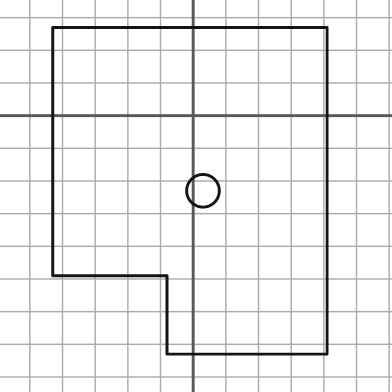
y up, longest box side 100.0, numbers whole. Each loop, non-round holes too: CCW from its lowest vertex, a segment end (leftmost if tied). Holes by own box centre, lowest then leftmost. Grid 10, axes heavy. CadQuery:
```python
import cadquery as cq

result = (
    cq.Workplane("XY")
    .moveTo(-8.0, -73.0)
    .lineTo(41.0, -73.0)
    .lineTo(41.0, 27.0)
    .lineTo(-43.0, 27.0)
    .lineTo(-43.0, -49.0)
    .lineTo(-8.0, -49.0)
    .close()
    .moveTo(3.0, -23.0)
    .circle(5.0)
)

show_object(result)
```